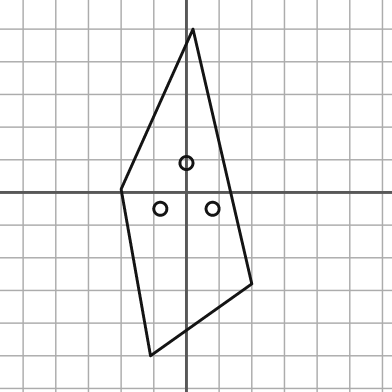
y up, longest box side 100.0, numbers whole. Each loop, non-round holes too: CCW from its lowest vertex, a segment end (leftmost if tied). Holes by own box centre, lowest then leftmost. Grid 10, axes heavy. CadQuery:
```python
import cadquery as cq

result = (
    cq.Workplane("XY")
    .moveTo(-11.0, -50.0)
    .lineTo(20.0, -28.0)
    .lineTo(2.0, 50.0)
    .lineTo(-20.0, 1.0)
    .close()
    .moveTo(-8.0, -5.0)
    .circle(2.0)
    .moveTo(8.0, -5.0)
    .circle(2.0)
    .moveTo(0.0, 9.0)
    .circle(2.0)
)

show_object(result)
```